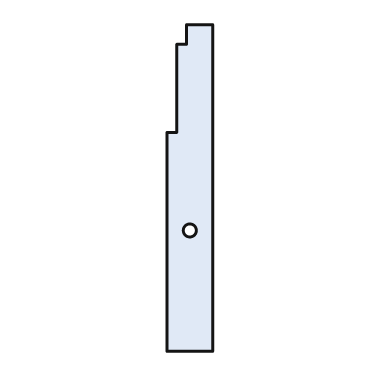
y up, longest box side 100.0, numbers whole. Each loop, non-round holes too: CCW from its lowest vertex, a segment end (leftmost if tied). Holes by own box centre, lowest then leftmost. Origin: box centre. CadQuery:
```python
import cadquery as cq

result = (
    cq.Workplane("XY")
    .moveTo(-7.0, -50.0)
    .lineTo(7.0, -50.0)
    .lineTo(7.0, 50.0)
    .lineTo(-1.0, 50.0)
    .lineTo(-1.0, 44.0)
    .lineTo(-4.0, 44.0)
    .lineTo(-4.0, 17.0)
    .lineTo(-7.0, 17.0)
    .close()
    .moveTo(0.0, -13.0)
    .circle(2.0)
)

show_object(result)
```